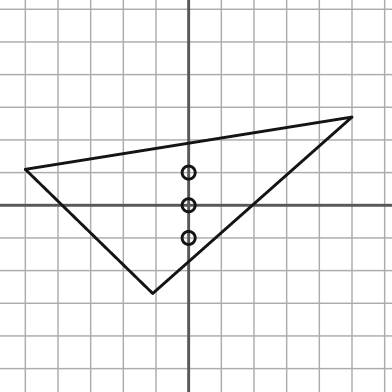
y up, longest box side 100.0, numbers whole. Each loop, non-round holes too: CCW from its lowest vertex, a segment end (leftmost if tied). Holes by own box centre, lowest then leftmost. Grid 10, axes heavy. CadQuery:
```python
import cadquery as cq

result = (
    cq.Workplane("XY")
    .moveTo(-11.0, -27.0)
    .lineTo(50.0, 27.0)
    .lineTo(-50.0, 11.0)
    .close()
    .moveTo(0.0, -10.0)
    .circle(2.0)
    .moveTo(0.0, 0.0)
    .circle(2.0)
    .moveTo(0.0, 10.0)
    .circle(2.0)
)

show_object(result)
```